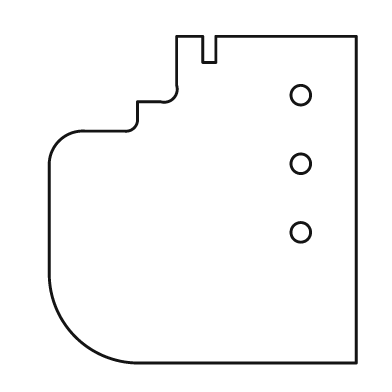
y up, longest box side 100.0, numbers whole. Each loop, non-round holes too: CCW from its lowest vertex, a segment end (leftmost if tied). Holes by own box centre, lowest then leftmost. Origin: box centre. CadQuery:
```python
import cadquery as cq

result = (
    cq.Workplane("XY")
    .moveTo(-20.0, -50.0)
    .lineTo(47.0, -50.0)
    .lineTo(47.0, 50.0)
    .lineTo(4.0, 50.0)
    .lineTo(4.0, 42.0)
    .lineTo(0.0, 42.0)
    .lineTo(0.0, 50.0)
    .lineTo(-8.0, 50.0)
    .lineTo(-8.0, 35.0)
    .threePointArc((-9.0, 31.0), (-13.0, 30.0))
    .lineTo(-20.0, 30.0)
    .lineTo(-20.0, 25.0)
    .threePointArc((-21.0, 22.0), (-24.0, 21.0))
    .lineTo(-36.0, 21.0)
    .threePointArc((-44.0, 18.0), (-47.0, 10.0))
    .lineTo(-47.0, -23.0)
    .threePointArc((-39.0, -42.0), (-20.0, -50.0))
    .close()
    .moveTo(30.0, -10.0)
    .circle(3.0)
    .moveTo(30.0, 11.0)
    .circle(3.0)
    .moveTo(30.0, 32.0)
    .circle(3.0)
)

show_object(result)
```